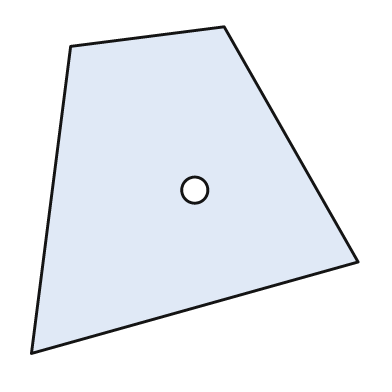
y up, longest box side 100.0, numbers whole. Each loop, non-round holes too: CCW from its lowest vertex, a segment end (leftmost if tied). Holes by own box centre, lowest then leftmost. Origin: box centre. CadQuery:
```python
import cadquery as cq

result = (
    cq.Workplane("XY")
    .moveTo(-50.0, -50.0)
    .lineTo(50.0, -22.0)
    .lineTo(9.0, 50.0)
    .lineTo(-38.0, 44.0)
    .close()
    .moveTo(0.0, 0.0)
    .circle(4.0)
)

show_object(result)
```